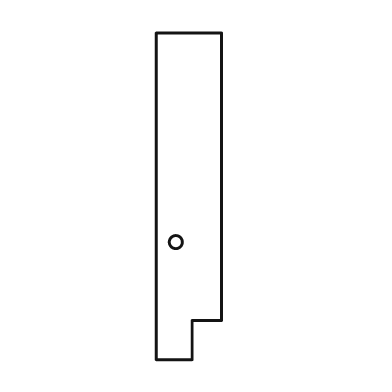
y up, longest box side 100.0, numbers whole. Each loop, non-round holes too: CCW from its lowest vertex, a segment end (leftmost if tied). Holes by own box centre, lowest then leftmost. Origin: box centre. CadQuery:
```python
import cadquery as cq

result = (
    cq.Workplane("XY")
    .moveTo(-10.0, -50.0)
    .lineTo(1.0, -50.0)
    .lineTo(1.0, -38.0)
    .lineTo(10.0, -38.0)
    .lineTo(10.0, 50.0)
    .lineTo(-10.0, 50.0)
    .close()
    .moveTo(-4.0, -14.0)
    .circle(2.0)
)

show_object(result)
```